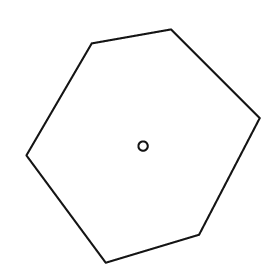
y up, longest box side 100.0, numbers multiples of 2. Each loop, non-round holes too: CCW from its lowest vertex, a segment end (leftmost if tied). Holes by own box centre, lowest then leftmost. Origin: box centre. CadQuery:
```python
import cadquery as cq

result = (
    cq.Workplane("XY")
    .moveTo(-16.0, -50.0)
    .lineTo(24.0, -38.0)
    .lineTo(50.0, 12.0)
    .lineTo(12.0, 50.0)
    .lineTo(-22.0, 44.0)
    .lineTo(-50.0, -4.0)
    .close()
    .moveTo(0.0, 0.0)
    .circle(2.0)
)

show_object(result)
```